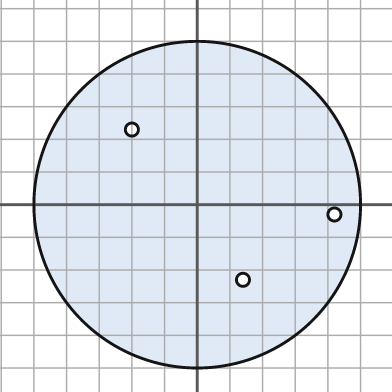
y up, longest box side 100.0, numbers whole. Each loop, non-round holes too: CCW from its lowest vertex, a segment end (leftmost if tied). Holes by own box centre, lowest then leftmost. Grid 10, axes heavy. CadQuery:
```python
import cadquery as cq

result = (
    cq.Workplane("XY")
    .moveTo(0.0, 0.0)
    .circle(50.0)
    .moveTo(14.0, -23.0)
    .circle(2.0)
    .moveTo(42.0, -3.0)
    .circle(2.0)
    .moveTo(-20.0, 23.0)
    .circle(2.0)
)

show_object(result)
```